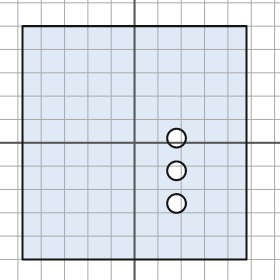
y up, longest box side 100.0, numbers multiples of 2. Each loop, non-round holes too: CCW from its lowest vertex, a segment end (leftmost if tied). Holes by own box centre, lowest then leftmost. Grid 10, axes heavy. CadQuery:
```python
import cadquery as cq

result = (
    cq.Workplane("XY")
    .moveTo(-48.0, -50.0)
    .lineTo(48.0, -50.0)
    .lineTo(48.0, 50.0)
    .lineTo(-48.0, 50.0)
    .close()
    .moveTo(18.0, -26.0)
    .circle(4.0)
    .moveTo(18.0, -12.0)
    .circle(4.0)
    .moveTo(18.0, 2.0)
    .circle(4.0)
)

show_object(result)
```